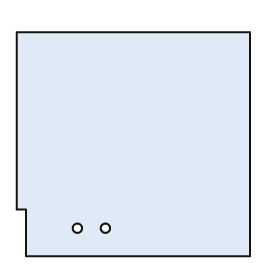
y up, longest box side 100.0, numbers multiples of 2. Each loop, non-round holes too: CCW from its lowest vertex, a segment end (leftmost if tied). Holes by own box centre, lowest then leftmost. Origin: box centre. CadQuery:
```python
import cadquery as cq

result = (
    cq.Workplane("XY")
    .moveTo(-46.0, -48.0)
    .lineTo(50.0, -48.0)
    .lineTo(50.0, 48.0)
    .lineTo(-50.0, 48.0)
    .lineTo(-50.0, -28.0)
    .lineTo(-46.0, -28.0)
    .close()
    .moveTo(-24.0, -36.0)
    .circle(2.0)
    .moveTo(-12.0, -36.0)
    .circle(2.0)
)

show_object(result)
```